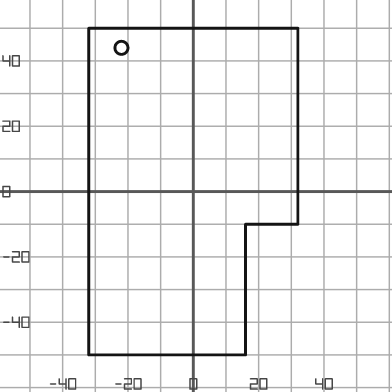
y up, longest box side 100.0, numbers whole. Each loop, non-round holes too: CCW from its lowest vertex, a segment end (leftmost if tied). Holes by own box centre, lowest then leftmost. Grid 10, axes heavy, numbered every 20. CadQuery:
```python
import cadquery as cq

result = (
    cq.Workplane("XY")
    .moveTo(-32.0, -50.0)
    .lineTo(16.0, -50.0)
    .lineTo(16.0, -10.0)
    .lineTo(32.0, -10.0)
    .lineTo(32.0, 50.0)
    .lineTo(-32.0, 50.0)
    .close()
    .moveTo(-22.0, 44.0)
    .circle(2.0)
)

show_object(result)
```